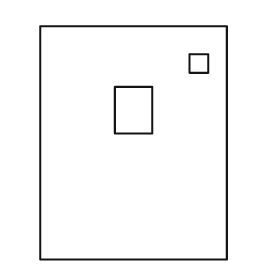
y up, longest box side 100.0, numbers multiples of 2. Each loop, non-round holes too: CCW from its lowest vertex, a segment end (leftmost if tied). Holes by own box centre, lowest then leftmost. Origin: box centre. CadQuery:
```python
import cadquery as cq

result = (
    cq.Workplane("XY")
    .moveTo(-40.0, -50.0)
    .lineTo(40.0, -50.0)
    .lineTo(40.0, 50.0)
    .lineTo(-40.0, 50.0)
    .close()
    .moveTo(-8.0, 4.0)
    .lineTo(8.0, 4.0)
    .lineTo(8.0, 24.0)
    .lineTo(-8.0, 24.0)
    .close()
    .moveTo(24.0, 30.0)
    .lineTo(32.0, 30.0)
    .lineTo(32.0, 38.0)
    .lineTo(24.0, 38.0)
    .close()
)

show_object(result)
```